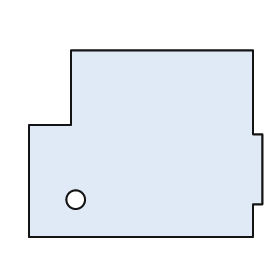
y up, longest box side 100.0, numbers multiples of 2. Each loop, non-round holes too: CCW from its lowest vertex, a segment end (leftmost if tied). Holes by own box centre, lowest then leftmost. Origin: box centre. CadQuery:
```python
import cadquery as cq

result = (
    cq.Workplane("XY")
    .moveTo(-50.0, -40.0)
    .lineTo(46.0, -40.0)
    .lineTo(46.0, -26.0)
    .lineTo(50.0, -26.0)
    .lineTo(50.0, 4.0)
    .lineTo(46.0, 4.0)
    .lineTo(46.0, 40.0)
    .lineTo(-32.0, 40.0)
    .lineTo(-32.0, 8.0)
    .lineTo(-50.0, 8.0)
    .close()
    .moveTo(-30.0, -24.0)
    .circle(4.0)
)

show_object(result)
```